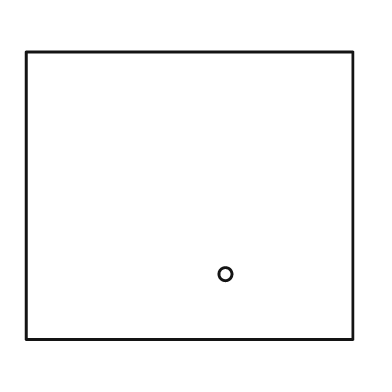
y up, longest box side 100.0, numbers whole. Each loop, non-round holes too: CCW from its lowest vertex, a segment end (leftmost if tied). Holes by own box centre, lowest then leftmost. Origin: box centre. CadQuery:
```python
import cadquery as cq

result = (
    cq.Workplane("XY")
    .moveTo(-50.0, -44.0)
    .lineTo(50.0, -44.0)
    .lineTo(50.0, 44.0)
    .lineTo(-50.0, 44.0)
    .close()
    .moveTo(11.0, -24.0)
    .circle(2.0)
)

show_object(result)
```